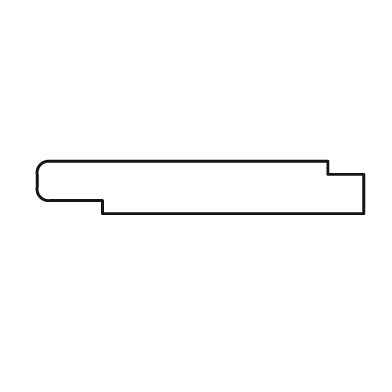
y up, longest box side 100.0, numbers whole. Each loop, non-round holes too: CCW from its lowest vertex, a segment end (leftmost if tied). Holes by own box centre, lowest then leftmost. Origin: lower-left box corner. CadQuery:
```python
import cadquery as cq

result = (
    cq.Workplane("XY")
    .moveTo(20.0, 0.0)
    .lineTo(100.0, 0.0)
    .lineTo(100.0, 12.0)
    .lineTo(89.0, 12.0)
    .lineTo(89.0, 16.0)
    .lineTo(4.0, 16.0)
    .threePointArc((1.0, 15.0), (0.0, 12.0))
    .lineTo(0.0, 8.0)
    .threePointArc((1.0, 5.0), (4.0, 4.0))
    .lineTo(20.0, 4.0)
    .close()
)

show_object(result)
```